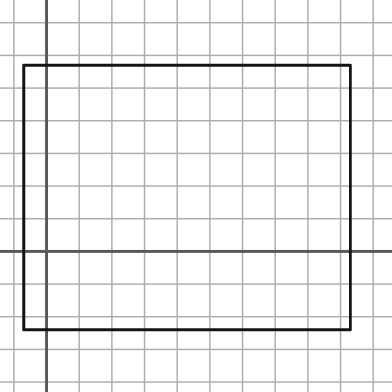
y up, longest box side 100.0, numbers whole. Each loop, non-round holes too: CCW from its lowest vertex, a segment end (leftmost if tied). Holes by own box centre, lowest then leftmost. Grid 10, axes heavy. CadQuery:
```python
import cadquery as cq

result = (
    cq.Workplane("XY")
    .moveTo(-7.0, -24.0)
    .lineTo(93.0, -24.0)
    .lineTo(93.0, 57.0)
    .lineTo(-7.0, 57.0)
    .close()
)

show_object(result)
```